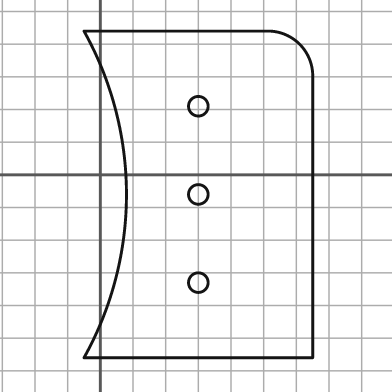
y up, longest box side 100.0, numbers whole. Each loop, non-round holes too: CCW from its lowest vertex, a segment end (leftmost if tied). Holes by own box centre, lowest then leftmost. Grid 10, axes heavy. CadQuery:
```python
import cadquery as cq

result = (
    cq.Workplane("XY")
    .moveTo(-5.0, -56.0)
    .lineTo(65.0, -56.0)
    .lineTo(65.0, 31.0)
    .threePointArc((61.0, 40.0), (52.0, 44.0))
    .lineTo(-5.0, 44.0)
    .threePointArc((8.0, -6.0), (-5.0, -56.0))
    .close()
    .moveTo(30.0, -33.0)
    .circle(3.0)
    .moveTo(30.0, -6.0)
    .circle(3.0)
    .moveTo(30.0, 21.0)
    .circle(3.0)
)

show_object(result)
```